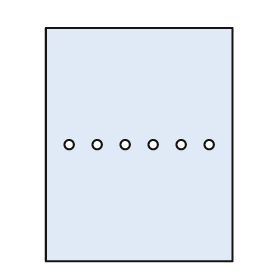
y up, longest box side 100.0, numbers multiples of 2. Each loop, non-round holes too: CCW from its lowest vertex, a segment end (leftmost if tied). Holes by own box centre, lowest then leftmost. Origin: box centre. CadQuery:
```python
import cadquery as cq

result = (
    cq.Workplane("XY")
    .moveTo(-40.0, -50.0)
    .lineTo(40.0, -50.0)
    .lineTo(40.0, 50.0)
    .lineTo(-40.0, 50.0)
    .close()
    .moveTo(-30.0, 0.0)
    .circle(2.0)
    .moveTo(-18.0, 0.0)
    .circle(2.0)
    .moveTo(-6.0, 0.0)
    .circle(2.0)
    .moveTo(6.0, 0.0)
    .circle(2.0)
    .moveTo(18.0, 0.0)
    .circle(2.0)
    .moveTo(30.0, 0.0)
    .circle(2.0)
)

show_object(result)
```